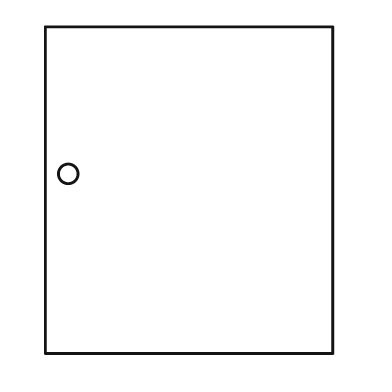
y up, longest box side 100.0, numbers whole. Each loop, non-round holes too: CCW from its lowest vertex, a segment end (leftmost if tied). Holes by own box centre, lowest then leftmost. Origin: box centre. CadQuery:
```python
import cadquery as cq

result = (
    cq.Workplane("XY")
    .moveTo(-44.0, -50.0)
    .lineTo(44.0, -50.0)
    .lineTo(44.0, 50.0)
    .lineTo(-44.0, 50.0)
    .close()
    .moveTo(-37.0, 5.0)
    .circle(3.0)
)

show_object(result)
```